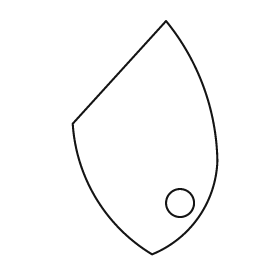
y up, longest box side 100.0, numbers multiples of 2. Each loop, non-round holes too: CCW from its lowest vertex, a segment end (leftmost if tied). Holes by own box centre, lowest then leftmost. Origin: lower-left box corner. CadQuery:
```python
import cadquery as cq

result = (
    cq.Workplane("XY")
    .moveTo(34.0, 0.0)
    .threePointArc((54.0, 16.0), (62.0, 40.0))
    .threePointArc((56.0, 72.0), (40.0, 100.0))
    .lineTo(0.0, 56.0)
    .threePointArc((10.0, 24.0), (34.0, 0.0))
    .close()
    .moveTo(46.0, 22.0)
    .circle(6.0)
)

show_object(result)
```